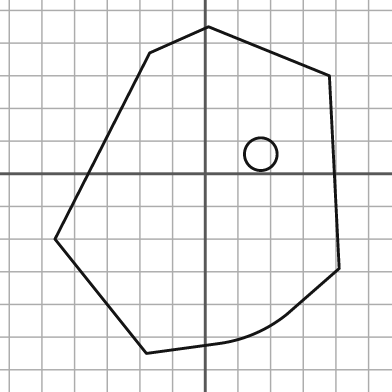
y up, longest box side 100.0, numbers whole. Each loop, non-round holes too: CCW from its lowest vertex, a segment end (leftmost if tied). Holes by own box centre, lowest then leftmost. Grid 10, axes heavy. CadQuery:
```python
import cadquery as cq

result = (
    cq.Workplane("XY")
    .moveTo(-18.0, -55.0)
    .lineTo(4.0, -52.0)
    .threePointArc((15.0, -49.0), (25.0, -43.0))
    .lineTo(41.0, -29.0)
    .lineTo(38.0, 30.0)
    .lineTo(1.0, 45.0)
    .lineTo(-17.0, 37.0)
    .lineTo(-46.0, -20.0)
    .close()
    .moveTo(17.0, 6.0)
    .circle(5.0)
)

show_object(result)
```